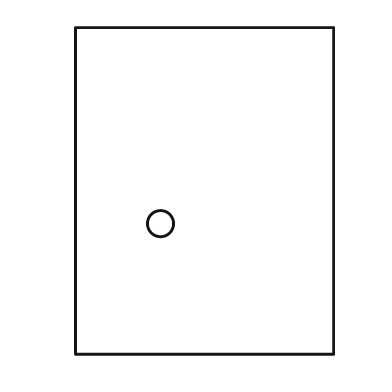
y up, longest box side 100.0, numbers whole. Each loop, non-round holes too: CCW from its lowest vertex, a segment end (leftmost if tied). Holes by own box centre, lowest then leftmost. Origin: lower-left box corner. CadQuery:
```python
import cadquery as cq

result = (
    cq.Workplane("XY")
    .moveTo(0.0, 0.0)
    .lineTo(79.0, 0.0)
    .lineTo(79.0, 100.0)
    .lineTo(0.0, 100.0)
    .close()
    .moveTo(26.0, 40.0)
    .circle(4.0)
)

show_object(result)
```